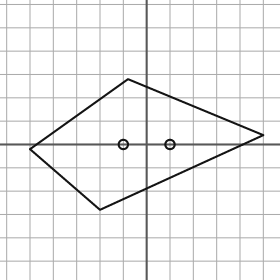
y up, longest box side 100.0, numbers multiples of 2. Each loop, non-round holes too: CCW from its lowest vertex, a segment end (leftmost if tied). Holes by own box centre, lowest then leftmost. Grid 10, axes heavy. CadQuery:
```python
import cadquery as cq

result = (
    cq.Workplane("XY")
    .moveTo(-20.0, -28.0)
    .lineTo(50.0, 4.0)
    .lineTo(-8.0, 28.0)
    .lineTo(-50.0, -2.0)
    .close()
    .moveTo(-10.0, 0.0)
    .circle(2.0)
    .moveTo(10.0, 0.0)
    .circle(2.0)
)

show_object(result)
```